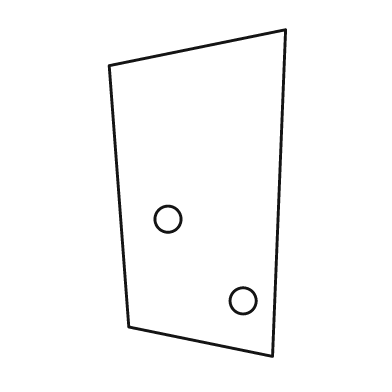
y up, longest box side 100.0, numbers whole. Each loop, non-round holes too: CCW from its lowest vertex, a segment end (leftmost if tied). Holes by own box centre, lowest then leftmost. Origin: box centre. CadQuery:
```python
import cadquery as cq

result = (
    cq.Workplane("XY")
    .moveTo(23.0, -50.0)
    .lineTo(27.0, 50.0)
    .lineTo(-27.0, 39.0)
    .lineTo(-21.0, -41.0)
    .close()
    .moveTo(14.0, -33.0)
    .circle(4.0)
    .moveTo(-9.0, -8.0)
    .circle(4.0)
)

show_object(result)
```